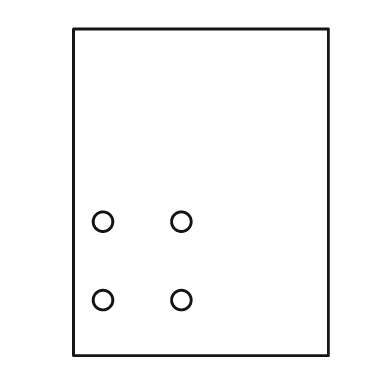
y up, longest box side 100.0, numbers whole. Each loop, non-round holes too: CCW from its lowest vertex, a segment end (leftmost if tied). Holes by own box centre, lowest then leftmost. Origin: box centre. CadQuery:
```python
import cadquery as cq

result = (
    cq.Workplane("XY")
    .moveTo(-39.0, -50.0)
    .lineTo(39.0, -50.0)
    .lineTo(39.0, 50.0)
    .lineTo(-39.0, 50.0)
    .close()
    .moveTo(-30.0, -33.0)
    .circle(3.0)
    .moveTo(-6.0, -33.0)
    .circle(3.0)
    .moveTo(-30.0, -9.0)
    .circle(3.0)
    .moveTo(-6.0, -9.0)
    .circle(3.0)
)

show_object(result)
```